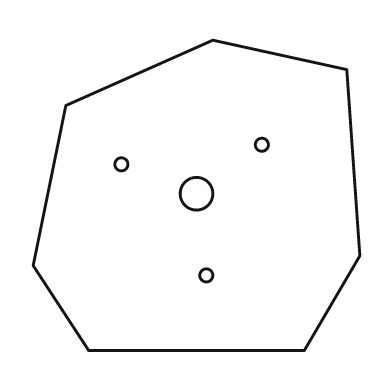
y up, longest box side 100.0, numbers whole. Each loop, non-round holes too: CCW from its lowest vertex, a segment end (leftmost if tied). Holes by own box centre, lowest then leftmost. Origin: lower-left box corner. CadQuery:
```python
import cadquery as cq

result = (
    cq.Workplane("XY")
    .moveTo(17.0, 0.0)
    .lineTo(83.0, 0.0)
    .lineTo(100.0, 29.0)
    .lineTo(96.0, 86.0)
    .lineTo(55.0, 95.0)
    .lineTo(10.0, 75.0)
    .lineTo(0.0, 26.0)
    .close()
    .moveTo(53.0, 23.0)
    .circle(2.0)
    .moveTo(50.0, 48.0)
    .circle(5.0)
    .moveTo(27.0, 57.0)
    .circle(2.0)
    .moveTo(70.0, 63.0)
    .circle(2.0)
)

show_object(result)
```